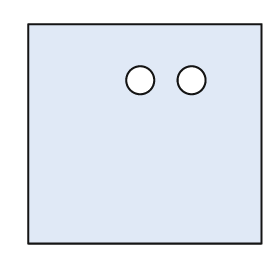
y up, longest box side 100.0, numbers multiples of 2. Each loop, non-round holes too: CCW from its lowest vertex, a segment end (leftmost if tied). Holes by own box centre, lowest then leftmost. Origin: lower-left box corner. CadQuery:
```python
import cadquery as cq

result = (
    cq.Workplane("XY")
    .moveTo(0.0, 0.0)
    .lineTo(100.0, 0.0)
    .lineTo(100.0, 94.0)
    .lineTo(0.0, 94.0)
    .close()
    .moveTo(48.0, 70.0)
    .circle(6.0)
    .moveTo(70.0, 70.0)
    .circle(6.0)
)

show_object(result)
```